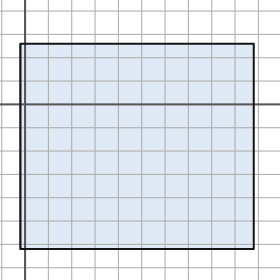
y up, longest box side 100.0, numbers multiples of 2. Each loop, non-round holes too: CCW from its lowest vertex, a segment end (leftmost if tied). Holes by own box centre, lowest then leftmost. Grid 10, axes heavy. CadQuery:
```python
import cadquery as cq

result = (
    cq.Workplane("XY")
    .moveTo(-2.0, -62.0)
    .lineTo(98.0, -62.0)
    .lineTo(98.0, 26.0)
    .lineTo(-2.0, 26.0)
    .close()
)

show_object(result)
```